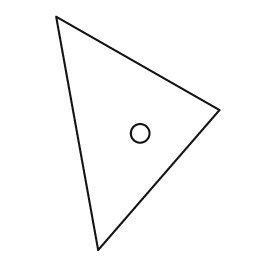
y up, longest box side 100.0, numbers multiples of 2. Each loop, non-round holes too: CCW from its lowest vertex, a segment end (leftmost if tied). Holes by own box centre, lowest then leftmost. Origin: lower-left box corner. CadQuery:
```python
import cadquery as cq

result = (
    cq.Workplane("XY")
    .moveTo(18.0, 0.0)
    .lineTo(70.0, 60.0)
    .lineTo(0.0, 100.0)
    .close()
    .moveTo(36.0, 50.0)
    .circle(4.0)
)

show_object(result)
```